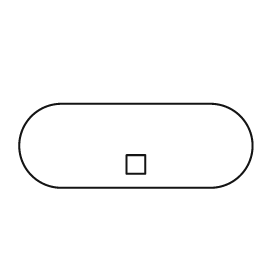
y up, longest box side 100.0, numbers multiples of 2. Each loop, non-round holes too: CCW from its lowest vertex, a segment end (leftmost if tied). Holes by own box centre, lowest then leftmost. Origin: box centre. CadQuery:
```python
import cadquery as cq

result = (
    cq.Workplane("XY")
    .moveTo(-32.0, -18.0)
    .lineTo(32.0, -18.0)
    .threePointArc((50.0, 0.0), (32.0, 18.0))
    .lineTo(-32.0, 18.0)
    .threePointArc((-50.0, 0.0), (-32.0, -18.0))
    .close()
    .moveTo(-4.0, -12.0)
    .lineTo(4.0, -12.0)
    .lineTo(4.0, -4.0)
    .lineTo(-4.0, -4.0)
    .close()
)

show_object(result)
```